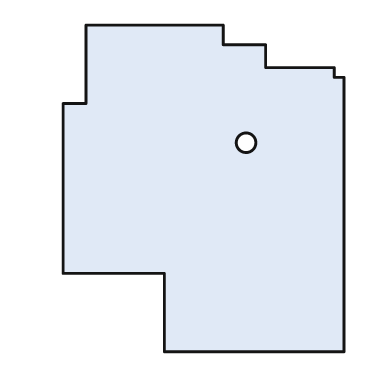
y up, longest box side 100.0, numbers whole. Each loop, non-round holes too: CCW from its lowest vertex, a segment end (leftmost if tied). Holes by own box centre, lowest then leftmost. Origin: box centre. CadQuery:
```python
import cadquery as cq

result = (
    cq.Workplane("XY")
    .moveTo(-12.0, -50.0)
    .lineTo(43.0, -50.0)
    .lineTo(43.0, 34.0)
    .lineTo(40.0, 34.0)
    .lineTo(40.0, 37.0)
    .lineTo(19.0, 37.0)
    .lineTo(19.0, 44.0)
    .lineTo(6.0, 44.0)
    .lineTo(6.0, 50.0)
    .lineTo(-36.0, 50.0)
    .lineTo(-36.0, 26.0)
    .lineTo(-43.0, 26.0)
    .lineTo(-43.0, -26.0)
    .lineTo(-12.0, -26.0)
    .close()
    .moveTo(13.0, 14.0)
    .circle(3.0)
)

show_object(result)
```